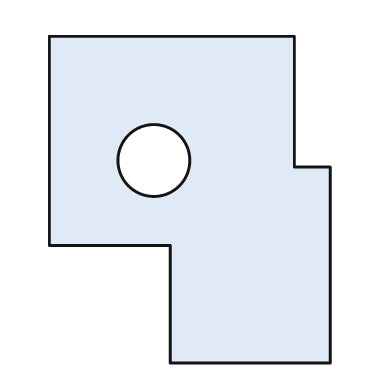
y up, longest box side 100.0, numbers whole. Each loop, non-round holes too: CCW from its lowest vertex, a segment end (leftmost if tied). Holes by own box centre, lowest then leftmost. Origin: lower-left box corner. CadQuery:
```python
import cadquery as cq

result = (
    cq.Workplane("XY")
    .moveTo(37.0, 0.0)
    .lineTo(86.0, 0.0)
    .lineTo(86.0, 60.0)
    .lineTo(75.0, 60.0)
    .lineTo(75.0, 100.0)
    .lineTo(0.0, 100.0)
    .lineTo(0.0, 36.0)
    .lineTo(37.0, 36.0)
    .close()
    .moveTo(32.0, 62.0)
    .circle(11.0)
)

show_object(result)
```